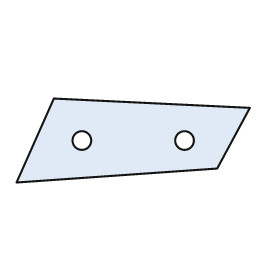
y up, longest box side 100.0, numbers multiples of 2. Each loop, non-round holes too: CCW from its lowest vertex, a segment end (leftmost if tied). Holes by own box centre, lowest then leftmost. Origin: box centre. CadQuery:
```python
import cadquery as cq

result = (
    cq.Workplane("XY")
    .moveTo(-50.0, -18.0)
    .lineTo(36.0, -12.0)
    .lineTo(50.0, 14.0)
    .lineTo(-34.0, 18.0)
    .close()
    .moveTo(-22.0, 0.0)
    .circle(4.0)
    .moveTo(22.0, 0.0)
    .circle(4.0)
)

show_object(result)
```